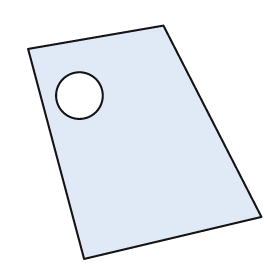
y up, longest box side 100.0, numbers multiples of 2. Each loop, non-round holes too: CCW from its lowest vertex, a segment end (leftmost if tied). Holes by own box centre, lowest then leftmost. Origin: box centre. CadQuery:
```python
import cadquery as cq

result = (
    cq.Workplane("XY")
    .moveTo(-26.0, -50.0)
    .lineTo(50.0, -32.0)
    .lineTo(8.0, 50.0)
    .lineTo(-50.0, 40.0)
    .close()
    .moveTo(-28.0, 20.0)
    .circle(10.0)
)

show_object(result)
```